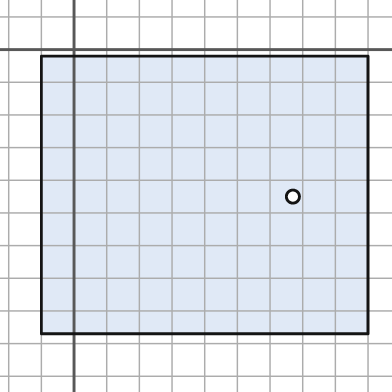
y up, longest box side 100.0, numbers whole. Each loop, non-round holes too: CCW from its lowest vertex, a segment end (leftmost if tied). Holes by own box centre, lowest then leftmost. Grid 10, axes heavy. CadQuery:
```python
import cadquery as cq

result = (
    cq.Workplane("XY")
    .moveTo(-10.0, -87.0)
    .lineTo(90.0, -87.0)
    .lineTo(90.0, -2.0)
    .lineTo(-10.0, -2.0)
    .close()
    .moveTo(67.0, -45.0)
    .circle(2.0)
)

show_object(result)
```